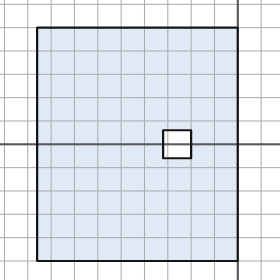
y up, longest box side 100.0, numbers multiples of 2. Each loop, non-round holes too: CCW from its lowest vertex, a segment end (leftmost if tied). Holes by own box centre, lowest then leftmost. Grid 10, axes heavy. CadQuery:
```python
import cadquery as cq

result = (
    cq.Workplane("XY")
    .moveTo(-86.0, -50.0)
    .lineTo(0.0, -50.0)
    .lineTo(0.0, 50.0)
    .lineTo(-86.0, 50.0)
    .close()
    .moveTo(-32.0, -6.0)
    .lineTo(-20.0, -6.0)
    .lineTo(-20.0, 6.0)
    .lineTo(-32.0, 6.0)
    .close()
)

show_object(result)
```